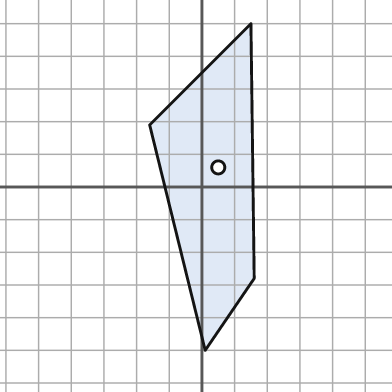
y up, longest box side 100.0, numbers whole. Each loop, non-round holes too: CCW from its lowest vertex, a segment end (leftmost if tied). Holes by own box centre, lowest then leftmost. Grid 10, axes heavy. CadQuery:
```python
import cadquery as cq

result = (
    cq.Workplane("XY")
    .moveTo(1.0, -50.0)
    .lineTo(16.0, -28.0)
    .lineTo(15.0, 50.0)
    .lineTo(-16.0, 19.0)
    .close()
    .moveTo(5.0, 6.0)
    .circle(2.0)
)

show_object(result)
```